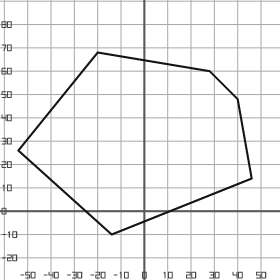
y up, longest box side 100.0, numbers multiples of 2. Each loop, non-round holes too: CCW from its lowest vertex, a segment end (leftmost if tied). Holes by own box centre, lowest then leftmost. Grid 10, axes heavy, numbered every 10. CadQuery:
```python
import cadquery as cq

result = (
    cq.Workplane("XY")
    .moveTo(-14.0, -10.0)
    .lineTo(46.0, 14.0)
    .lineTo(40.0, 48.0)
    .lineTo(28.0, 60.0)
    .lineTo(-20.0, 68.0)
    .lineTo(-54.0, 26.0)
    .close()
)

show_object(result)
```